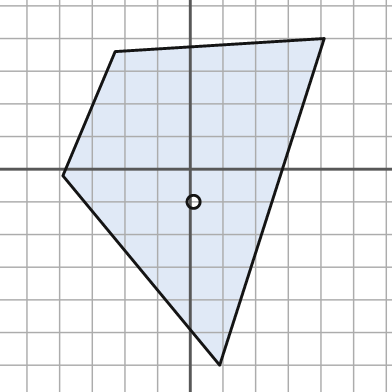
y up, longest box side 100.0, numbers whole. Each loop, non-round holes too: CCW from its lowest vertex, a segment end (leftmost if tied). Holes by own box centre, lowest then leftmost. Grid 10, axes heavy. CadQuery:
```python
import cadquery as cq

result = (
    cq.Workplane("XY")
    .moveTo(9.0, -60.0)
    .lineTo(41.0, 40.0)
    .lineTo(-23.0, 36.0)
    .lineTo(-39.0, -2.0)
    .close()
    .moveTo(1.0, -10.0)
    .circle(2.0)
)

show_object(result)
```